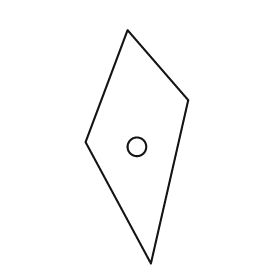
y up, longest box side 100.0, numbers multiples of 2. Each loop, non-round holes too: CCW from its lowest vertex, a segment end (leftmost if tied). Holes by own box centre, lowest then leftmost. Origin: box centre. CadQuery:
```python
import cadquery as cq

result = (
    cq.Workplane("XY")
    .moveTo(6.0, -50.0)
    .lineTo(22.0, 20.0)
    .lineTo(-4.0, 50.0)
    .lineTo(-22.0, 2.0)
    .close()
    .moveTo(0.0, 0.0)
    .circle(4.0)
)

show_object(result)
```